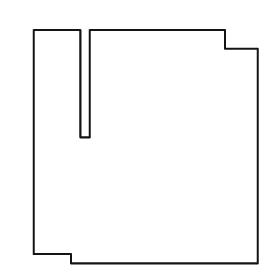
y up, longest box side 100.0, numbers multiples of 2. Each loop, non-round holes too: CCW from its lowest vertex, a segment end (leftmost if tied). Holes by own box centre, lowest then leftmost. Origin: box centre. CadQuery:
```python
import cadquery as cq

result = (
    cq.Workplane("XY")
    .moveTo(-32.0, -50.0)
    .lineTo(48.0, -50.0)
    .lineTo(48.0, 42.0)
    .lineTo(34.0, 42.0)
    .lineTo(34.0, 50.0)
    .lineTo(-24.0, 50.0)
    .lineTo(-24.0, 4.0)
    .lineTo(-28.0, 4.0)
    .lineTo(-28.0, 50.0)
    .lineTo(-48.0, 50.0)
    .lineTo(-48.0, -46.0)
    .lineTo(-32.0, -46.0)
    .close()
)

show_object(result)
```